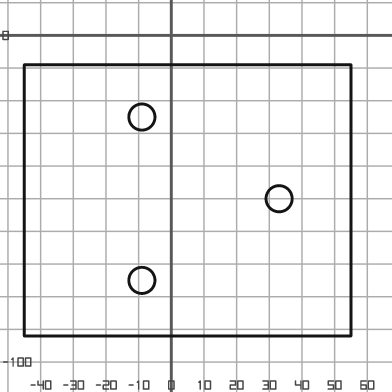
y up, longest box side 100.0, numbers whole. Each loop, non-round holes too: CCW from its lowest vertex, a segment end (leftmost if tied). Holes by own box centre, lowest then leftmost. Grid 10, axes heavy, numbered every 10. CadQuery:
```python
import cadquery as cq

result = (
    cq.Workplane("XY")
    .moveTo(-45.0, -92.0)
    .lineTo(55.0, -92.0)
    .lineTo(55.0, -9.0)
    .lineTo(-45.0, -9.0)
    .close()
    .moveTo(-9.0, -75.0)
    .circle(4.0)
    .moveTo(33.0, -50.0)
    .circle(4.0)
    .moveTo(-9.0, -25.0)
    .circle(4.0)
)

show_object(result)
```